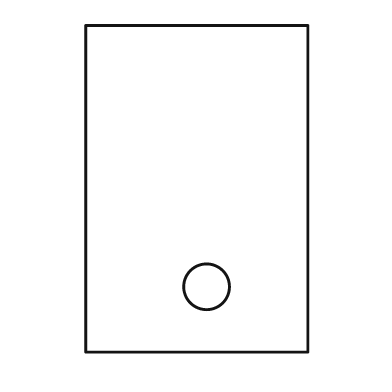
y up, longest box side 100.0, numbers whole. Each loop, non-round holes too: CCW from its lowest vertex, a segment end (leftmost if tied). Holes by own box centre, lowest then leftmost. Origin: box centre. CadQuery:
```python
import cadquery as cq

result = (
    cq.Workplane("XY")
    .moveTo(-34.0, -50.0)
    .lineTo(34.0, -50.0)
    .lineTo(34.0, 50.0)
    .lineTo(-34.0, 50.0)
    .close()
    .moveTo(3.0, -30.0)
    .circle(7.0)
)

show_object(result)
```